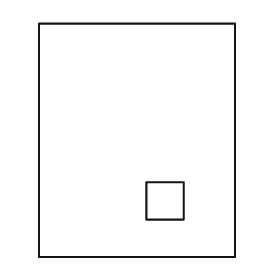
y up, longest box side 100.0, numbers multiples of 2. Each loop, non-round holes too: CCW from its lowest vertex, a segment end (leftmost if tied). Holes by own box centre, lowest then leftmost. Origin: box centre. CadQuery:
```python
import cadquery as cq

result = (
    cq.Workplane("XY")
    .moveTo(-42.0, -50.0)
    .lineTo(42.0, -50.0)
    .lineTo(42.0, 50.0)
    .lineTo(-42.0, 50.0)
    .close()
    .moveTo(4.0, -34.0)
    .lineTo(20.0, -34.0)
    .lineTo(20.0, -18.0)
    .lineTo(4.0, -18.0)
    .close()
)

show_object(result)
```